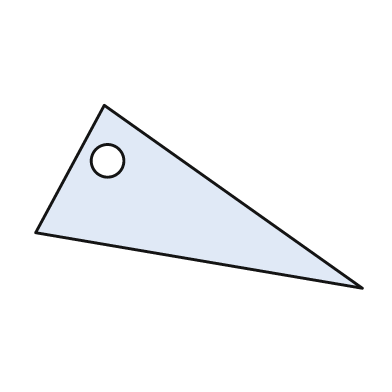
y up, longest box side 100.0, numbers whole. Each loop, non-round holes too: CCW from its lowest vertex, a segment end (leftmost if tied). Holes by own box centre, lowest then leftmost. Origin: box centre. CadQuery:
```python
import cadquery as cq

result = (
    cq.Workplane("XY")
    .moveTo(50.0, -28.0)
    .lineTo(-29.0, 28.0)
    .lineTo(-50.0, -11.0)
    .close()
    .moveTo(-28.0, 11.0)
    .circle(5.0)
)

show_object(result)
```